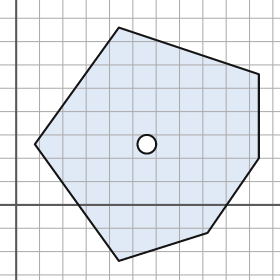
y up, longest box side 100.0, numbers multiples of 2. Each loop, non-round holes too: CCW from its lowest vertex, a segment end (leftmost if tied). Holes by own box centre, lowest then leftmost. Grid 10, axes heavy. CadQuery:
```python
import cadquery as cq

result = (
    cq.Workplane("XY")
    .moveTo(44.0, -24.0)
    .lineTo(82.0, -12.0)
    .lineTo(104.0, 20.0)
    .lineTo(104.0, 56.0)
    .lineTo(44.0, 76.0)
    .lineTo(8.0, 26.0)
    .close()
    .moveTo(56.0, 26.0)
    .circle(4.0)
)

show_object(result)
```